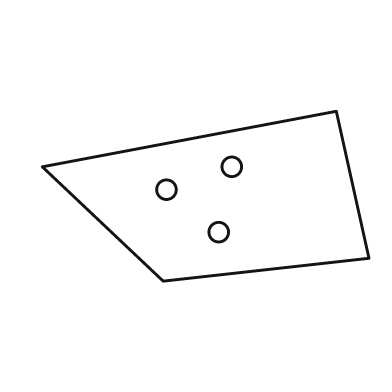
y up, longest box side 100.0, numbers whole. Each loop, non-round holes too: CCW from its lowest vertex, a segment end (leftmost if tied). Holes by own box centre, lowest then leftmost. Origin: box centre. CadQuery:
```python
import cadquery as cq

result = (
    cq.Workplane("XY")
    .moveTo(-13.0, -26.0)
    .lineTo(50.0, -19.0)
    .lineTo(40.0, 26.0)
    .lineTo(-50.0, 9.0)
    .close()
    .moveTo(4.0, -11.0)
    .circle(3.0)
    .moveTo(-12.0, 2.0)
    .circle(3.0)
    .moveTo(8.0, 9.0)
    .circle(3.0)
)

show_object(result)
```